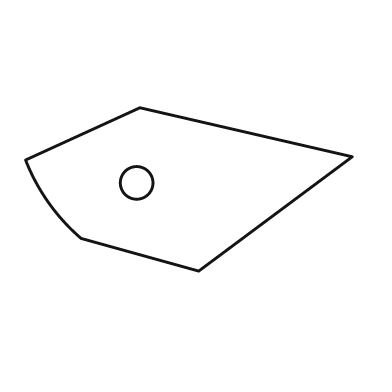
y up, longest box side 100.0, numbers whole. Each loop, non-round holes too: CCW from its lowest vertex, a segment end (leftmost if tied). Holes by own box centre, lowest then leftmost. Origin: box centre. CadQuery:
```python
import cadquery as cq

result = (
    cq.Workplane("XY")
    .moveTo(3.0, -25.0)
    .lineTo(50.0, 10.0)
    .lineTo(-15.0, 25.0)
    .lineTo(-50.0, 9.0)
    .threePointArc((-43.0, -4.0), (-33.0, -15.0))
    .close()
    .moveTo(-16.0, 2.0)
    .circle(5.0)
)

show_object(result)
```